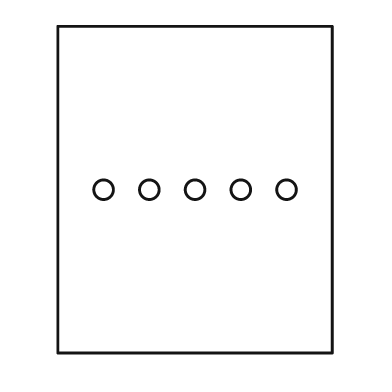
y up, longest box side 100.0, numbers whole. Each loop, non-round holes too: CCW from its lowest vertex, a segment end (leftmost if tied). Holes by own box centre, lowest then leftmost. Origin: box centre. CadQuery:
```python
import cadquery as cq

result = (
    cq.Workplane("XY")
    .moveTo(-42.0, -50.0)
    .lineTo(42.0, -50.0)
    .lineTo(42.0, 50.0)
    .lineTo(-42.0, 50.0)
    .close()
    .moveTo(-28.0, 0.0)
    .circle(3.0)
    .moveTo(-14.0, 0.0)
    .circle(3.0)
    .moveTo(0.0, 0.0)
    .circle(3.0)
    .moveTo(14.0, 0.0)
    .circle(3.0)
    .moveTo(28.0, 0.0)
    .circle(3.0)
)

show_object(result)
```